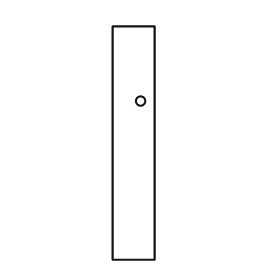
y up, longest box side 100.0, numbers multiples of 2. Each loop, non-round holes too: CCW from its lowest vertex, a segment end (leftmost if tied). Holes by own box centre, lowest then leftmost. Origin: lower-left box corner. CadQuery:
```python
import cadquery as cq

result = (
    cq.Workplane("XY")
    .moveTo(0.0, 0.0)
    .lineTo(18.0, 0.0)
    .lineTo(18.0, 100.0)
    .lineTo(0.0, 100.0)
    .close()
    .moveTo(12.0, 68.0)
    .circle(2.0)
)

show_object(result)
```